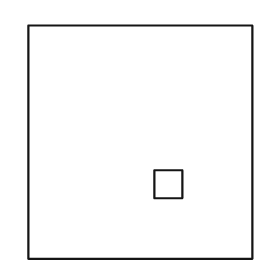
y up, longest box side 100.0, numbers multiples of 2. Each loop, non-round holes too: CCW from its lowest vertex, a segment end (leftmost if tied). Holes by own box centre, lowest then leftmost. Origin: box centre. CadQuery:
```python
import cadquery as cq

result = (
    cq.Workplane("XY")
    .moveTo(-48.0, -50.0)
    .lineTo(48.0, -50.0)
    .lineTo(48.0, 50.0)
    .lineTo(-48.0, 50.0)
    .close()
    .moveTo(6.0, -24.0)
    .lineTo(18.0, -24.0)
    .lineTo(18.0, -12.0)
    .lineTo(6.0, -12.0)
    .close()
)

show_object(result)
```